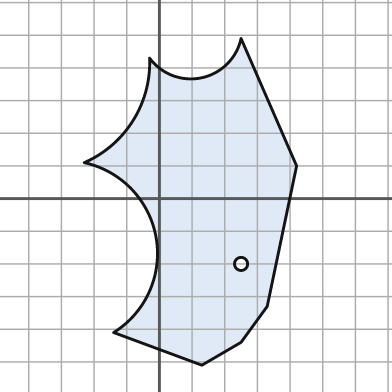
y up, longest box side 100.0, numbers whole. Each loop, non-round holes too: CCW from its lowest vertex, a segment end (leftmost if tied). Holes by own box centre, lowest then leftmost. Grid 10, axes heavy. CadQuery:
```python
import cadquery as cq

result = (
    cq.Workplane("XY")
    .moveTo(13.0, -51.0)
    .lineTo(25.0, -44.0)
    .lineTo(33.0, -33.0)
    .lineTo(42.0, 10.0)
    .lineTo(25.0, 49.0)
    .threePointArc((13.0, 37.0), (-3.0, 43.0))
    .threePointArc((-8.0, 24.0), (-23.0, 11.0))
    .threePointArc((-1.0, -12.0), (-14.0, -41.0))
    .close()
    .moveTo(25.0, -20.0)
    .circle(2.0)
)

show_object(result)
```